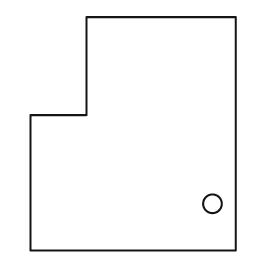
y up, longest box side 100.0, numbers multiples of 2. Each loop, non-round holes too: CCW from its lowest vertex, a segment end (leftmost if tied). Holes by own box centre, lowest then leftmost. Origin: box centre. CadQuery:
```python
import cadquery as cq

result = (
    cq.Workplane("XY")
    .moveTo(-44.0, -50.0)
    .lineTo(44.0, -50.0)
    .lineTo(44.0, 50.0)
    .lineTo(-20.0, 50.0)
    .lineTo(-20.0, 8.0)
    .lineTo(-44.0, 8.0)
    .close()
    .moveTo(34.0, -30.0)
    .circle(4.0)
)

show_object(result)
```